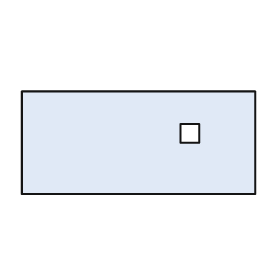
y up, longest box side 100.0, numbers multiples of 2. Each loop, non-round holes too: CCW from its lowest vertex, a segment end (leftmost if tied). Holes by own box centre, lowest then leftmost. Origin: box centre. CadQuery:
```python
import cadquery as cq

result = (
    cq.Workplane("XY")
    .moveTo(-50.0, -22.0)
    .lineTo(50.0, -22.0)
    .lineTo(50.0, 22.0)
    .lineTo(-50.0, 22.0)
    .close()
    .moveTo(18.0, 0.0)
    .lineTo(26.0, 0.0)
    .lineTo(26.0, 8.0)
    .lineTo(18.0, 8.0)
    .close()
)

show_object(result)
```